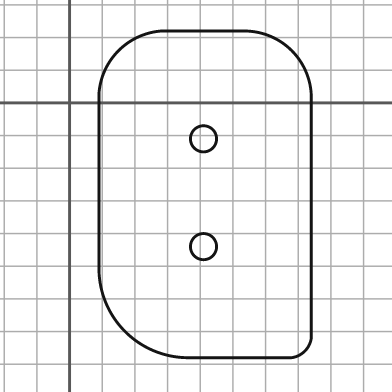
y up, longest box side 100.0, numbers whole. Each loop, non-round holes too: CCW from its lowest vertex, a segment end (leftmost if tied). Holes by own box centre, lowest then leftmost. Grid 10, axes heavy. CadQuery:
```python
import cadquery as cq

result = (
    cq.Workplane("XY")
    .moveTo(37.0, -78.0)
    .lineTo(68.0, -78.0)
    .threePointArc((72.0, -76.0), (74.0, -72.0))
    .lineTo(74.0, 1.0)
    .threePointArc((68.0, 16.0), (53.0, 22.0))
    .lineTo(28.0, 22.0)
    .threePointArc((15.0, 16.0), (9.0, 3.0))
    .lineTo(9.0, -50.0)
    .threePointArc((17.0, -70.0), (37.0, -78.0))
    .close()
    .moveTo(41.0, -44.0)
    .circle(4.0)
    .moveTo(41.0, -11.0)
    .circle(4.0)
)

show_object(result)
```